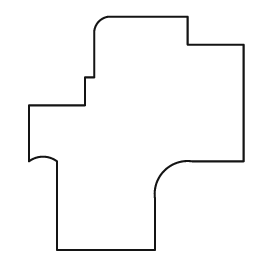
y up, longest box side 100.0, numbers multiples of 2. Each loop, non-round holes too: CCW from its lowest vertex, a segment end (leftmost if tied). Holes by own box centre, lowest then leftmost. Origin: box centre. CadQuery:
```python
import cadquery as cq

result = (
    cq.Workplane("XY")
    .moveTo(-34.0, -50.0)
    .lineTo(8.0, -50.0)
    .lineTo(8.0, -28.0)
    .threePointArc((12.0, -16.0), (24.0, -12.0))
    .lineTo(46.0, -12.0)
    .lineTo(46.0, 38.0)
    .lineTo(22.0, 38.0)
    .lineTo(22.0, 50.0)
    .lineTo(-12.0, 50.0)
    .threePointArc((-16.0, 48.0), (-18.0, 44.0))
    .lineTo(-18.0, 24.0)
    .lineTo(-22.0, 24.0)
    .lineTo(-22.0, 12.0)
    .lineTo(-46.0, 12.0)
    .lineTo(-46.0, -12.0)
    .threePointArc((-40.0, -10.0), (-34.0, -12.0))
    .close()
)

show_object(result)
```